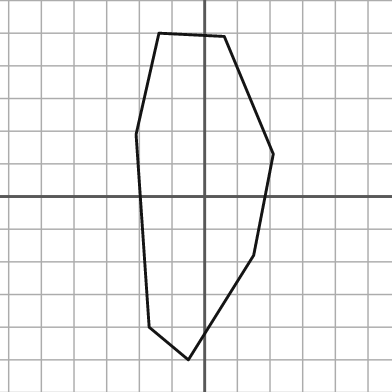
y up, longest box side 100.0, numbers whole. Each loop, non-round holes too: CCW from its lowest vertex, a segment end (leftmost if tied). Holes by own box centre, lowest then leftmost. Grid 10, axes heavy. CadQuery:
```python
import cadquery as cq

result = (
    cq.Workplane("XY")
    .moveTo(-5.0, -50.0)
    .lineTo(15.0, -18.0)
    .lineTo(21.0, 13.0)
    .lineTo(6.0, 49.0)
    .lineTo(-14.0, 50.0)
    .lineTo(-21.0, 19.0)
    .lineTo(-17.0, -40.0)
    .close()
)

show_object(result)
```